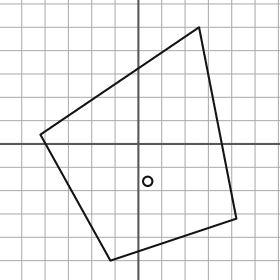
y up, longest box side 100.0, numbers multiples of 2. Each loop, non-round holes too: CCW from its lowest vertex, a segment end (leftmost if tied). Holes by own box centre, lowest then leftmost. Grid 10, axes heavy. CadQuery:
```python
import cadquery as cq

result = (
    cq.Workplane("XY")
    .moveTo(-12.0, -50.0)
    .lineTo(42.0, -32.0)
    .lineTo(26.0, 50.0)
    .lineTo(-42.0, 4.0)
    .close()
    .moveTo(4.0, -16.0)
    .circle(2.0)
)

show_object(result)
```